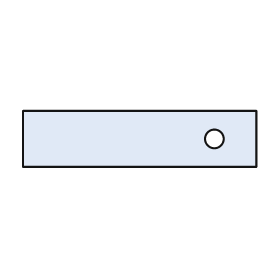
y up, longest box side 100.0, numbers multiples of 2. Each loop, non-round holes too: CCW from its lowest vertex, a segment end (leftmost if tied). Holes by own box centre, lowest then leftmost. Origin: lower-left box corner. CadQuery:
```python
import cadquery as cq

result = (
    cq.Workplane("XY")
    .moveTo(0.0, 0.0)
    .lineTo(100.0, 0.0)
    .lineTo(100.0, 24.0)
    .lineTo(0.0, 24.0)
    .close()
    .moveTo(82.0, 12.0)
    .circle(4.0)
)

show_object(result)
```